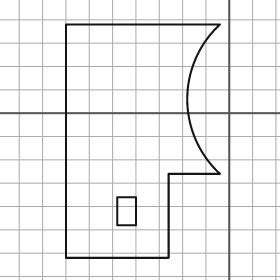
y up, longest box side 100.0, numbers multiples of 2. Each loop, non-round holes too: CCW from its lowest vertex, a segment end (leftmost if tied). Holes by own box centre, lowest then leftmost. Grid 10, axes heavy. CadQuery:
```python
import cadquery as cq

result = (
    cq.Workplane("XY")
    .moveTo(-70.0, -62.0)
    .lineTo(-26.0, -62.0)
    .lineTo(-26.0, -26.0)
    .lineTo(-4.0, -26.0)
    .threePointArc((-18.0, 6.0), (-4.0, 38.0))
    .lineTo(-70.0, 38.0)
    .close()
    .moveTo(-48.0, -48.0)
    .lineTo(-40.0, -48.0)
    .lineTo(-40.0, -36.0)
    .lineTo(-48.0, -36.0)
    .close()
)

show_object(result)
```